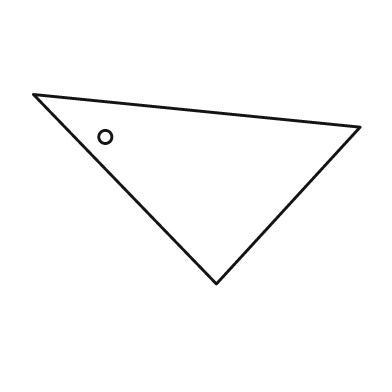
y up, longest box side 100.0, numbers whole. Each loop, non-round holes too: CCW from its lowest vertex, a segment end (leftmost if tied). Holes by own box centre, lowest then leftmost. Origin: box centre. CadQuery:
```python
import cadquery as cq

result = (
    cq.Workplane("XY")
    .moveTo(6.0, -29.0)
    .lineTo(50.0, 19.0)
    .lineTo(-50.0, 29.0)
    .close()
    .moveTo(-28.0, 16.0)
    .circle(2.0)
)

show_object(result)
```